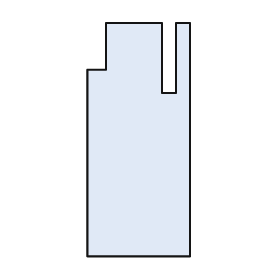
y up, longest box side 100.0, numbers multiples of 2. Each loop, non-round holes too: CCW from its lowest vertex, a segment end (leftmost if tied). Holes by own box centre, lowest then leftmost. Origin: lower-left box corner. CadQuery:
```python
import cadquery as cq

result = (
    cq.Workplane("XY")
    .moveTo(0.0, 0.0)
    .lineTo(44.0, 0.0)
    .lineTo(44.0, 100.0)
    .lineTo(38.0, 100.0)
    .lineTo(38.0, 70.0)
    .lineTo(32.0, 70.0)
    .lineTo(32.0, 100.0)
    .lineTo(8.0, 100.0)
    .lineTo(8.0, 80.0)
    .lineTo(0.0, 80.0)
    .close()
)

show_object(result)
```